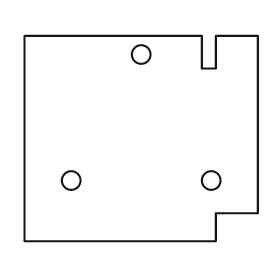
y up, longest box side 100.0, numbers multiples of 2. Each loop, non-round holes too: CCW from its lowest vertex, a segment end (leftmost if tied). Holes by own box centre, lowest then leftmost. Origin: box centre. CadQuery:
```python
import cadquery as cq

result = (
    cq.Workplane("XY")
    .moveTo(-50.0, -44.0)
    .lineTo(32.0, -44.0)
    .lineTo(32.0, -32.0)
    .lineTo(50.0, -32.0)
    .lineTo(50.0, 44.0)
    .lineTo(32.0, 44.0)
    .lineTo(32.0, 30.0)
    .lineTo(26.0, 30.0)
    .lineTo(26.0, 44.0)
    .lineTo(-50.0, 44.0)
    .close()
    .moveTo(-30.0, -18.0)
    .circle(4.0)
    .moveTo(30.0, -18.0)
    .circle(4.0)
    .moveTo(0.0, 36.0)
    .circle(4.0)
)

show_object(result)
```